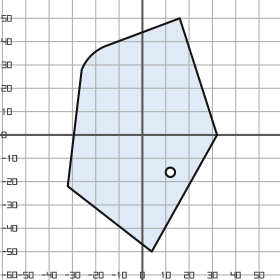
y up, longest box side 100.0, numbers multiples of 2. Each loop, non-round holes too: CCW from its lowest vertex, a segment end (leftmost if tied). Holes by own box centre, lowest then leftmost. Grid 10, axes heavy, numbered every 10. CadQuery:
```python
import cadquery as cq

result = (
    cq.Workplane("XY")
    .moveTo(4.0, -50.0)
    .lineTo(32.0, 0.0)
    .lineTo(16.0, 50.0)
    .lineTo(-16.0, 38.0)
    .threePointArc((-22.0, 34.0), (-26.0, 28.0))
    .lineTo(-32.0, -22.0)
    .close()
    .moveTo(12.0, -16.0)
    .circle(2.0)
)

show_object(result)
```